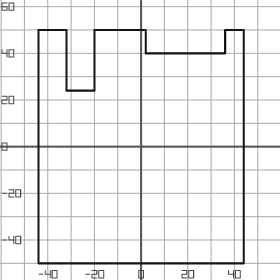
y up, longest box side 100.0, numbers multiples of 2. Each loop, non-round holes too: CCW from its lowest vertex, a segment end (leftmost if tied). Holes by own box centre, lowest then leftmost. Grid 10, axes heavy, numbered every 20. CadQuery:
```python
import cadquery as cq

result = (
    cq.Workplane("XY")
    .moveTo(-44.0, -50.0)
    .lineTo(44.0, -50.0)
    .lineTo(44.0, 50.0)
    .lineTo(36.0, 50.0)
    .lineTo(36.0, 40.0)
    .lineTo(2.0, 40.0)
    .lineTo(2.0, 50.0)
    .lineTo(-20.0, 50.0)
    .lineTo(-20.0, 24.0)
    .lineTo(-32.0, 24.0)
    .lineTo(-32.0, 50.0)
    .lineTo(-44.0, 50.0)
    .close()
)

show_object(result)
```